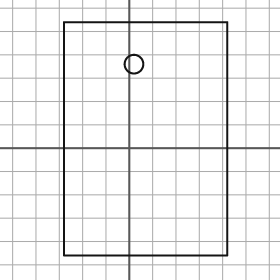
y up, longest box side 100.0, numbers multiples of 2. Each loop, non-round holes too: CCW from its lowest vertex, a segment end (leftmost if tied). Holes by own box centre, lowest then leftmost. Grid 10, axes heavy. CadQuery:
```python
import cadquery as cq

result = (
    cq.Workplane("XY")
    .moveTo(-28.0, -46.0)
    .lineTo(42.0, -46.0)
    .lineTo(42.0, 54.0)
    .lineTo(-28.0, 54.0)
    .close()
    .moveTo(2.0, 36.0)
    .circle(4.0)
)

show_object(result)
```